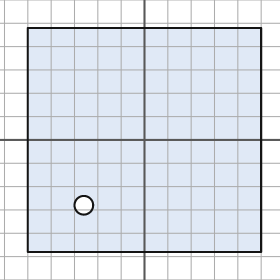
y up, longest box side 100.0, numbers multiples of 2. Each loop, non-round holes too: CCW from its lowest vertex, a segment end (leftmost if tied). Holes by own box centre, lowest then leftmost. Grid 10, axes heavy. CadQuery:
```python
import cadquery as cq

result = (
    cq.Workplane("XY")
    .moveTo(-50.0, -48.0)
    .lineTo(50.0, -48.0)
    .lineTo(50.0, 48.0)
    .lineTo(-50.0, 48.0)
    .close()
    .moveTo(-26.0, -28.0)
    .circle(4.0)
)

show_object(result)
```